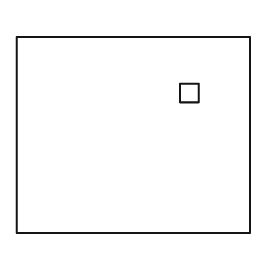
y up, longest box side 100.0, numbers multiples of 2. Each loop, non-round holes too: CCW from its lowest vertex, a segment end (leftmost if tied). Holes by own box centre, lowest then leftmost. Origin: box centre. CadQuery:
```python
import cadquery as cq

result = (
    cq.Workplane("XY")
    .moveTo(-50.0, -42.0)
    .lineTo(50.0, -42.0)
    .lineTo(50.0, 42.0)
    .lineTo(-50.0, 42.0)
    .close()
    .moveTo(20.0, 14.0)
    .lineTo(28.0, 14.0)
    .lineTo(28.0, 22.0)
    .lineTo(20.0, 22.0)
    .close()
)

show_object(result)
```